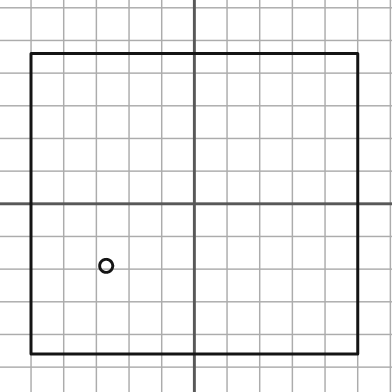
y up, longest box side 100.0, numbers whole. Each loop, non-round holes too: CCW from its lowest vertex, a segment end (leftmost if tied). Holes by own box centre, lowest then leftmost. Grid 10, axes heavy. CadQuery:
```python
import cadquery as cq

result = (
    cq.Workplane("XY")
    .moveTo(-50.0, -46.0)
    .lineTo(50.0, -46.0)
    .lineTo(50.0, 46.0)
    .lineTo(-50.0, 46.0)
    .close()
    .moveTo(-27.0, -19.0)
    .circle(2.0)
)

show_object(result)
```